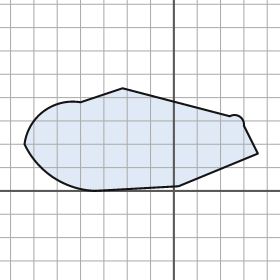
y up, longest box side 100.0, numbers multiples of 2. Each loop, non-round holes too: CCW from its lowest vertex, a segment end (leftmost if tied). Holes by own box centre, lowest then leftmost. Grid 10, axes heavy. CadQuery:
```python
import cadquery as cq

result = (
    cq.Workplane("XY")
    .moveTo(-34.0, 0.0)
    .lineTo(2.0, 2.0)
    .lineTo(36.0, 16.0)
    .lineTo(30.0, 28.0)
    .threePointArc((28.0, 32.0), (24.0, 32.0))
    .lineTo(-22.0, 44.0)
    .lineTo(-40.0, 38.0)
    .threePointArc((-56.0, 34.0), (-64.0, 20.0))
    .threePointArc((-52.0, 6.0), (-34.0, 0.0))
    .close()
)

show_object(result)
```